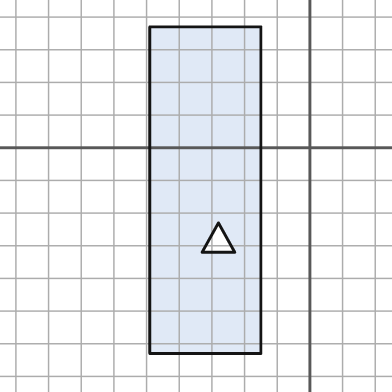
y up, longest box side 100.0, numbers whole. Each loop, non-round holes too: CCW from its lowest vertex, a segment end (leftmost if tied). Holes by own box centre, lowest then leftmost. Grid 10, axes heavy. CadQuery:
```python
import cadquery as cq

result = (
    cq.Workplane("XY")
    .moveTo(-49.0, -63.0)
    .lineTo(-15.0, -63.0)
    .lineTo(-15.0, 37.0)
    .lineTo(-49.0, 37.0)
    .close()
    .moveTo(-33.0, -32.0)
    .lineTo(-23.0, -32.0)
    .lineTo(-28.0, -23.0)
    .close()
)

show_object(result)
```